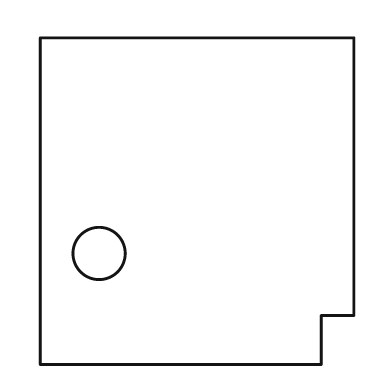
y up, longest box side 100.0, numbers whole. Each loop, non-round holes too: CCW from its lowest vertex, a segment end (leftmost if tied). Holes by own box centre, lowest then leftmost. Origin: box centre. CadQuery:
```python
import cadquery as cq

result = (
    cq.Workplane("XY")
    .moveTo(-48.0, -50.0)
    .lineTo(38.0, -50.0)
    .lineTo(38.0, -35.0)
    .lineTo(48.0, -35.0)
    .lineTo(48.0, 50.0)
    .lineTo(-48.0, 50.0)
    .close()
    .moveTo(-30.0, -16.0)
    .circle(8.0)
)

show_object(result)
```